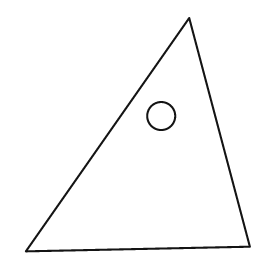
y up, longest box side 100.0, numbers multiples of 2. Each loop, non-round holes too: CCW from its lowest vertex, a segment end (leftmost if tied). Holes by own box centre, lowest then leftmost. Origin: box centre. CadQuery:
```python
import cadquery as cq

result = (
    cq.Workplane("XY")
    .moveTo(-48.0, -50.0)
    .lineTo(48.0, -48.0)
    .lineTo(22.0, 50.0)
    .close()
    .moveTo(10.0, 8.0)
    .circle(6.0)
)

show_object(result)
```